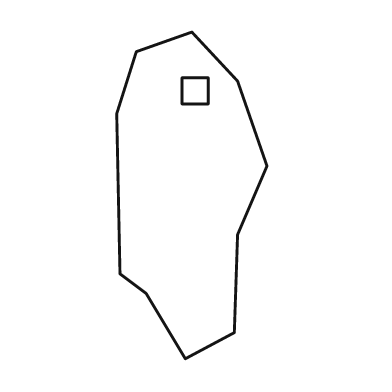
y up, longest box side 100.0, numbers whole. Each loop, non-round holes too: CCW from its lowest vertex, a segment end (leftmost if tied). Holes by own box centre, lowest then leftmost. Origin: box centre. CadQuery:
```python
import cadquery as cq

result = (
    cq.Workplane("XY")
    .moveTo(-2.0, -50.0)
    .lineTo(13.0, -42.0)
    .lineTo(14.0, -12.0)
    .lineTo(23.0, 9.0)
    .lineTo(14.0, 35.0)
    .lineTo(0.0, 50.0)
    .lineTo(-17.0, 44.0)
    .lineTo(-23.0, 25.0)
    .lineTo(-22.0, -24.0)
    .lineTo(-14.0, -30.0)
    .close()
    .moveTo(-3.0, 28.0)
    .lineTo(5.0, 28.0)
    .lineTo(5.0, 36.0)
    .lineTo(-3.0, 36.0)
    .close()
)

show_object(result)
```